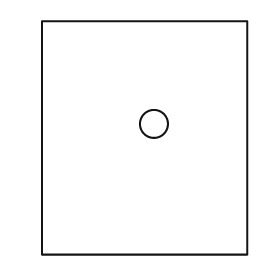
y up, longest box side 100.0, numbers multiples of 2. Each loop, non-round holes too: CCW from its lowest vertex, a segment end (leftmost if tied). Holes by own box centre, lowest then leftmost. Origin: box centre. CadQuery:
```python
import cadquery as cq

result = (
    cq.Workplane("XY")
    .moveTo(-44.0, -50.0)
    .lineTo(44.0, -50.0)
    .lineTo(44.0, 50.0)
    .lineTo(-44.0, 50.0)
    .close()
    .moveTo(4.0, 6.0)
    .circle(6.0)
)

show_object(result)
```